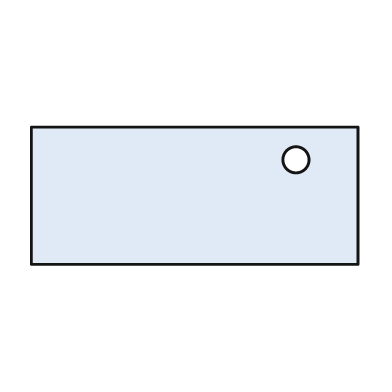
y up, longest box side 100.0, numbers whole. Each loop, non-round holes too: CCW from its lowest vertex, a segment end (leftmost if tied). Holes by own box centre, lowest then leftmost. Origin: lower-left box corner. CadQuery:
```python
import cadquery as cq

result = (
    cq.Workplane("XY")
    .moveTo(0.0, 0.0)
    .lineTo(100.0, 0.0)
    .lineTo(100.0, 42.0)
    .lineTo(0.0, 42.0)
    .close()
    .moveTo(81.0, 32.0)
    .circle(4.0)
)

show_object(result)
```